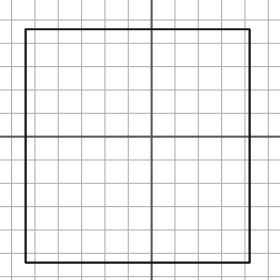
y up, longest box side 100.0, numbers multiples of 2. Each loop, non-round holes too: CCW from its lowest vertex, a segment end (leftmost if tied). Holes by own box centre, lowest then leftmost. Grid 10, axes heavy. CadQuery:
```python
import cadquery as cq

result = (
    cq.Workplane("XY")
    .moveTo(-54.0, -54.0)
    .lineTo(42.0, -54.0)
    .lineTo(42.0, 46.0)
    .lineTo(-54.0, 46.0)
    .close()
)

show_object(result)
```